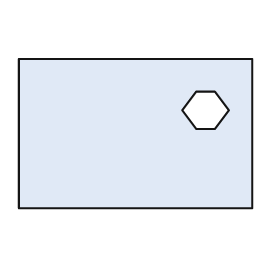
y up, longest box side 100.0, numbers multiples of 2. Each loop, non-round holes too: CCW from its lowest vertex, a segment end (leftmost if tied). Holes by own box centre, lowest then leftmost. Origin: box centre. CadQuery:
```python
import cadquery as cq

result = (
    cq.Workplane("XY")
    .moveTo(-50.0, -32.0)
    .lineTo(50.0, -32.0)
    .lineTo(50.0, 32.0)
    .lineTo(-50.0, 32.0)
    .close()
    .moveTo(26.0, 2.0)
    .lineTo(34.0, 2.0)
    .lineTo(40.0, 10.0)
    .lineTo(34.0, 18.0)
    .lineTo(26.0, 18.0)
    .lineTo(20.0, 10.0)
    .close()
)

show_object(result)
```